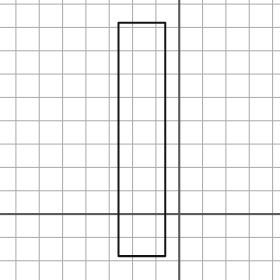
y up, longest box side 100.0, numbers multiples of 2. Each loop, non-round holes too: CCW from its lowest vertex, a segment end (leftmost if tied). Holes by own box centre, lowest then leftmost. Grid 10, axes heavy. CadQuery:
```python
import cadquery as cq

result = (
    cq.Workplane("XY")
    .moveTo(-26.0, -18.0)
    .lineTo(-6.0, -18.0)
    .lineTo(-6.0, 82.0)
    .lineTo(-26.0, 82.0)
    .close()
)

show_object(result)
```